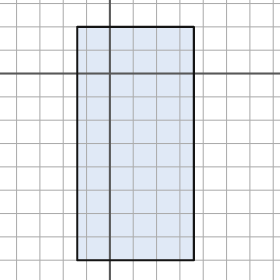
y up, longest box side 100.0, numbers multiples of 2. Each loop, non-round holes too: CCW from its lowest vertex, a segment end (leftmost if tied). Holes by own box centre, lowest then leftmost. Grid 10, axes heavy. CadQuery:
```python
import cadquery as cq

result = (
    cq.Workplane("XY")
    .moveTo(-14.0, -80.0)
    .lineTo(36.0, -80.0)
    .lineTo(36.0, 20.0)
    .lineTo(-14.0, 20.0)
    .close()
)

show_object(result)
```